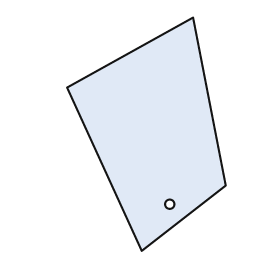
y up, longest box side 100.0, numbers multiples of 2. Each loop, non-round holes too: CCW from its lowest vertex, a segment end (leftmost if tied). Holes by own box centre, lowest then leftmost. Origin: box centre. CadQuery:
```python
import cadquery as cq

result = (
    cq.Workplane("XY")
    .moveTo(-2.0, -50.0)
    .lineTo(34.0, -22.0)
    .lineTo(20.0, 50.0)
    .lineTo(-34.0, 20.0)
    .close()
    .moveTo(10.0, -30.0)
    .circle(2.0)
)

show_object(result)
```